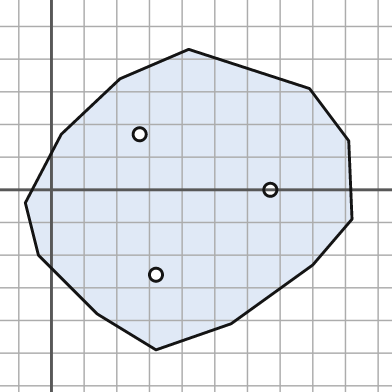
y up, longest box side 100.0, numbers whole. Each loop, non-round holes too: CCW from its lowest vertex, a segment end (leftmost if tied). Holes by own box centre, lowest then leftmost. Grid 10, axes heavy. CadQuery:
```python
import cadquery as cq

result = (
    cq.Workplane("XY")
    .moveTo(32.0, -49.0)
    .lineTo(55.0, -41.0)
    .lineTo(80.0, -23.0)
    .lineTo(92.0, -9.0)
    .lineTo(91.0, 15.0)
    .lineTo(79.0, 31.0)
    .lineTo(42.0, 43.0)
    .lineTo(21.0, 34.0)
    .lineTo(3.0, 17.0)
    .lineTo(-8.0, -4.0)
    .lineTo(-4.0, -20.0)
    .lineTo(14.0, -38.0)
    .close()
    .moveTo(32.0, -26.0)
    .circle(2.0)
    .moveTo(67.0, 0.0)
    .circle(2.0)
    .moveTo(27.0, 17.0)
    .circle(2.0)
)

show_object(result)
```